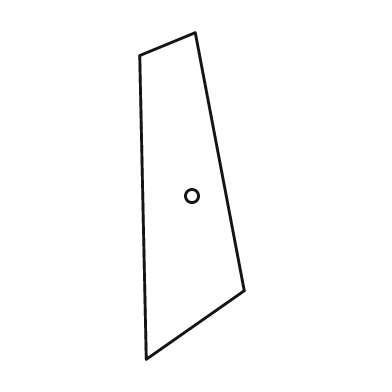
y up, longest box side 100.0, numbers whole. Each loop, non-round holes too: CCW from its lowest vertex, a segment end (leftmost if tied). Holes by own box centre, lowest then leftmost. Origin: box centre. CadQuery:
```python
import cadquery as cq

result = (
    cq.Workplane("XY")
    .moveTo(-14.0, -50.0)
    .lineTo(16.0, -29.0)
    .lineTo(1.0, 50.0)
    .lineTo(-16.0, 43.0)
    .close()
    .moveTo(0.0, 0.0)
    .circle(2.0)
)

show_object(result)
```